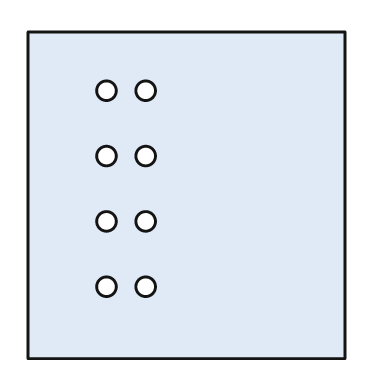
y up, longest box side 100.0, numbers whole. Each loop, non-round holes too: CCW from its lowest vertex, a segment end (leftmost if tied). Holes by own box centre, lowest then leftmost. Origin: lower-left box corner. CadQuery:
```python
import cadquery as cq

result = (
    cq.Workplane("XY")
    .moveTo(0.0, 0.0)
    .lineTo(97.0, 0.0)
    .lineTo(97.0, 100.0)
    .lineTo(0.0, 100.0)
    .close()
    .moveTo(24.0, 22.0)
    .circle(3.0)
    .moveTo(36.0, 22.0)
    .circle(3.0)
    .moveTo(24.0, 42.0)
    .circle(3.0)
    .moveTo(36.0, 42.0)
    .circle(3.0)
    .moveTo(24.0, 62.0)
    .circle(3.0)
    .moveTo(36.0, 62.0)
    .circle(3.0)
    .moveTo(24.0, 82.0)
    .circle(3.0)
    .moveTo(36.0, 82.0)
    .circle(3.0)
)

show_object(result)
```